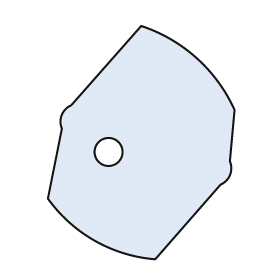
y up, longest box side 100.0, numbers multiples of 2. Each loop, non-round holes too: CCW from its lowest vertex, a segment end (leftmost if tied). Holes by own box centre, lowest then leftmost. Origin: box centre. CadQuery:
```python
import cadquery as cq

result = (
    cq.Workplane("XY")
    .moveTo(6.0, -50.0)
    .lineTo(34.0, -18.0)
    .threePointArc((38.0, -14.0), (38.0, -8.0))
    .lineTo(40.0, 14.0)
    .threePointArc((24.0, 36.0), (0.0, 50.0))
    .lineTo(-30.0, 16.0)
    .threePointArc((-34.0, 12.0), (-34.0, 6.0))
    .lineTo(-40.0, -24.0)
    .threePointArc((-20.0, -42.0), (6.0, -50.0))
    .close()
    .moveTo(-14.0, -4.0)
    .circle(6.0)
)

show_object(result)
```